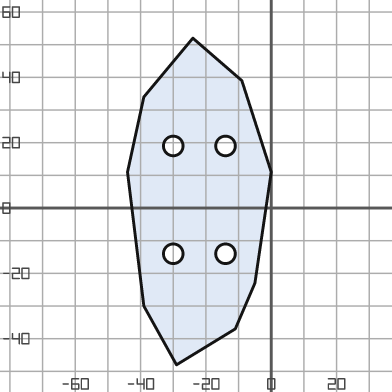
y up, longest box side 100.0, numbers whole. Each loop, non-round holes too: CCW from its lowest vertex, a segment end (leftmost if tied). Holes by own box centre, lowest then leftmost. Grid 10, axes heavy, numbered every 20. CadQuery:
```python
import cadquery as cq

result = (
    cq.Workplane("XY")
    .moveTo(-29.0, -48.0)
    .lineTo(-11.0, -37.0)
    .lineTo(-5.0, -23.0)
    .lineTo(0.0, 11.0)
    .lineTo(-9.0, 39.0)
    .lineTo(-24.0, 52.0)
    .lineTo(-39.0, 34.0)
    .lineTo(-44.0, 11.0)
    .lineTo(-39.0, -30.0)
    .close()
    .moveTo(-30.0, -14.0)
    .circle(3.0)
    .moveTo(-14.0, -14.0)
    .circle(3.0)
    .moveTo(-30.0, 19.0)
    .circle(3.0)
    .moveTo(-14.0, 19.0)
    .circle(3.0)
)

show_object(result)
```